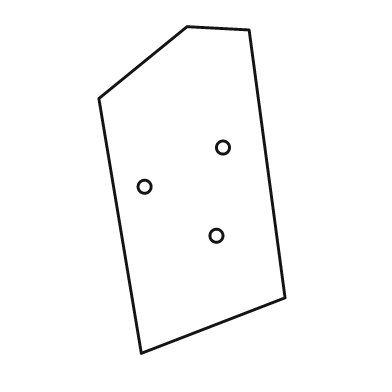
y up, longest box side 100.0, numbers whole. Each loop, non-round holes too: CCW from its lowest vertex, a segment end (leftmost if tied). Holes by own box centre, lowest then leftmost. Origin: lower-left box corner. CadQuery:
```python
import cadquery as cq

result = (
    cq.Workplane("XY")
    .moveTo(13.0, 0.0)
    .lineTo(57.0, 17.0)
    .lineTo(46.0, 99.0)
    .lineTo(27.0, 100.0)
    .lineTo(0.0, 78.0)
    .close()
    .moveTo(36.0, 36.0)
    .circle(2.0)
    .moveTo(14.0, 51.0)
    .circle(2.0)
    .moveTo(38.0, 63.0)
    .circle(2.0)
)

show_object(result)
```